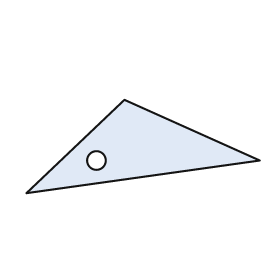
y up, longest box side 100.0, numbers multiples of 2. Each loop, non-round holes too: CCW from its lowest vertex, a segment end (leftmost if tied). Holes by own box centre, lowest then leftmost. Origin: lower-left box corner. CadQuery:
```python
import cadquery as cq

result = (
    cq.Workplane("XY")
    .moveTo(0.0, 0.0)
    .lineTo(100.0, 14.0)
    .lineTo(42.0, 40.0)
    .close()
    .moveTo(30.0, 14.0)
    .circle(4.0)
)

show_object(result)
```